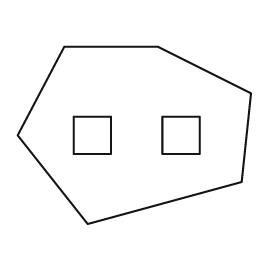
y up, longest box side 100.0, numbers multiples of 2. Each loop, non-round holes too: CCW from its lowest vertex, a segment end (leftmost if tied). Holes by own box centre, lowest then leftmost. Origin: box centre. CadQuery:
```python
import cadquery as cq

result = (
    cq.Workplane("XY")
    .moveTo(-20.0, -38.0)
    .lineTo(46.0, -20.0)
    .lineTo(50.0, 18.0)
    .lineTo(10.0, 38.0)
    .lineTo(-30.0, 38.0)
    .lineTo(-50.0, 0.0)
    .close()
    .moveTo(-26.0, -8.0)
    .lineTo(-10.0, -8.0)
    .lineTo(-10.0, 8.0)
    .lineTo(-26.0, 8.0)
    .close()
    .moveTo(12.0, -8.0)
    .lineTo(28.0, -8.0)
    .lineTo(28.0, 8.0)
    .lineTo(12.0, 8.0)
    .close()
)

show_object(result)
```